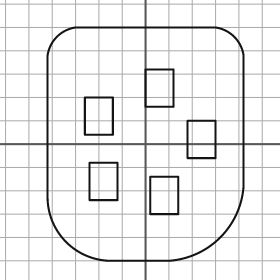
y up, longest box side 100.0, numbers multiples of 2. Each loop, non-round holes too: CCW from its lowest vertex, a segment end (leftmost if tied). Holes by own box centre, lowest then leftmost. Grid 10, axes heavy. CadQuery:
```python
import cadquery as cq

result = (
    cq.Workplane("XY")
    .moveTo(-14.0, -50.0)
    .lineTo(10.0, -50.0)
    .threePointArc((32.0, -40.0), (42.0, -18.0))
    .lineTo(42.0, 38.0)
    .threePointArc((38.0, 46.0), (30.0, 50.0))
    .lineTo(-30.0, 50.0)
    .threePointArc((-38.0, 46.0), (-42.0, 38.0))
    .lineTo(-42.0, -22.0)
    .threePointArc((-34.0, -42.0), (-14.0, -50.0))
    .close()
    .moveTo(2.0, -30.0)
    .lineTo(14.0, -30.0)
    .lineTo(14.0, -14.0)
    .lineTo(2.0, -14.0)
    .close()
    .moveTo(-24.0, -24.0)
    .lineTo(-12.0, -24.0)
    .lineTo(-12.0, -8.0)
    .lineTo(-24.0, -8.0)
    .close()
    .moveTo(18.0, -6.0)
    .lineTo(30.0, -6.0)
    .lineTo(30.0, 10.0)
    .lineTo(18.0, 10.0)
    .close()
    .moveTo(-26.0, 4.0)
    .lineTo(-14.0, 4.0)
    .lineTo(-14.0, 20.0)
    .lineTo(-26.0, 20.0)
    .close()
    .moveTo(0.0, 16.0)
    .lineTo(12.0, 16.0)
    .lineTo(12.0, 32.0)
    .lineTo(0.0, 32.0)
    .close()
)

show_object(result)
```